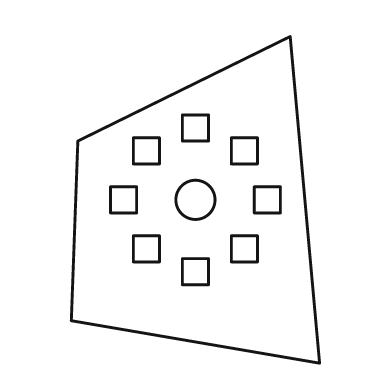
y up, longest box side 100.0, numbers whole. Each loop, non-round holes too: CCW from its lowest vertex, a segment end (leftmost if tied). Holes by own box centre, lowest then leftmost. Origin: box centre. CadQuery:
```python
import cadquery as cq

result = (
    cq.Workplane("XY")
    .moveTo(38.0, -50.0)
    .lineTo(29.0, 50.0)
    .lineTo(-36.0, 18.0)
    .lineTo(-38.0, -37.0)
    .close()
    .moveTo(-4.0, -26.0)
    .lineTo(4.0, -26.0)
    .lineTo(4.0, -18.0)
    .lineTo(-4.0, -18.0)
    .close()
    .moveTo(-19.0, -19.0)
    .lineTo(-11.0, -19.0)
    .lineTo(-11.0, -11.0)
    .lineTo(-19.0, -11.0)
    .close()
    .moveTo(11.0, -19.0)
    .lineTo(19.0, -19.0)
    .lineTo(19.0, -11.0)
    .lineTo(11.0, -11.0)
    .close()
    .moveTo(-26.0, -4.0)
    .lineTo(-18.0, -4.0)
    .lineTo(-18.0, 4.0)
    .lineTo(-26.0, 4.0)
    .close()
    .moveTo(0.0, 0.0)
    .circle(6.0)
    .moveTo(18.0, -4.0)
    .lineTo(26.0, -4.0)
    .lineTo(26.0, 4.0)
    .lineTo(18.0, 4.0)
    .close()
    .moveTo(-19.0, 11.0)
    .lineTo(-11.0, 11.0)
    .lineTo(-11.0, 19.0)
    .lineTo(-19.0, 19.0)
    .close()
    .moveTo(11.0, 11.0)
    .lineTo(19.0, 11.0)
    .lineTo(19.0, 19.0)
    .lineTo(11.0, 19.0)
    .close()
    .moveTo(-4.0, 18.0)
    .lineTo(4.0, 18.0)
    .lineTo(4.0, 26.0)
    .lineTo(-4.0, 26.0)
    .close()
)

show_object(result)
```